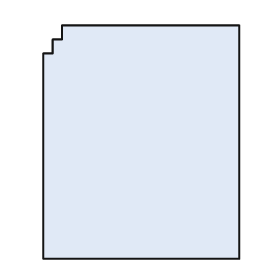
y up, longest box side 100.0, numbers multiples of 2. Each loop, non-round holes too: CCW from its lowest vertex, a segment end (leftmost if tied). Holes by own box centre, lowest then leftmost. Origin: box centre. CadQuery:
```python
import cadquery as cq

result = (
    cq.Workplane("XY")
    .moveTo(-42.0, -50.0)
    .lineTo(42.0, -50.0)
    .lineTo(42.0, 50.0)
    .lineTo(-34.0, 50.0)
    .lineTo(-34.0, 44.0)
    .lineTo(-38.0, 44.0)
    .lineTo(-38.0, 38.0)
    .lineTo(-42.0, 38.0)
    .close()
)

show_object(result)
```